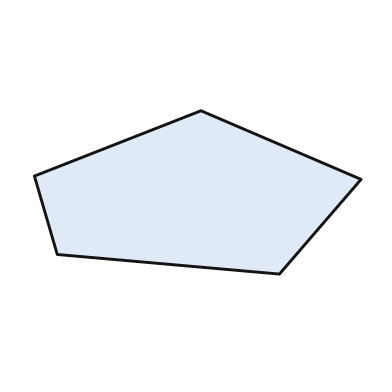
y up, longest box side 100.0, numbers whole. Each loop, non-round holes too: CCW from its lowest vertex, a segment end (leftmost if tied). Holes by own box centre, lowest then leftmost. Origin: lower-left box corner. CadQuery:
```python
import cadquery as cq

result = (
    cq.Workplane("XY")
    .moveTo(75.0, 0.0)
    .lineTo(100.0, 29.0)
    .lineTo(51.0, 50.0)
    .lineTo(0.0, 30.0)
    .lineTo(7.0, 6.0)
    .close()
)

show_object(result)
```